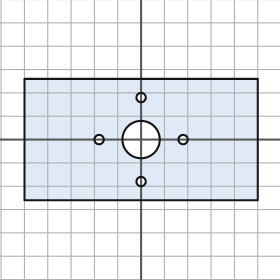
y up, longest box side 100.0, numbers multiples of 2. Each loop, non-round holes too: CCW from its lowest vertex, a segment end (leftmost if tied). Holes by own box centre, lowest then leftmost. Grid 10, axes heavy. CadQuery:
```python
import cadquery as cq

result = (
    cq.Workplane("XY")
    .moveTo(-50.0, -26.0)
    .lineTo(50.0, -26.0)
    .lineTo(50.0, 26.0)
    .lineTo(-50.0, 26.0)
    .close()
    .moveTo(0.0, -18.0)
    .circle(2.0)
    .moveTo(-18.0, 0.0)
    .circle(2.0)
    .moveTo(0.0, 0.0)
    .circle(8.0)
    .moveTo(18.0, 0.0)
    .circle(2.0)
    .moveTo(0.0, 18.0)
    .circle(2.0)
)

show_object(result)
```